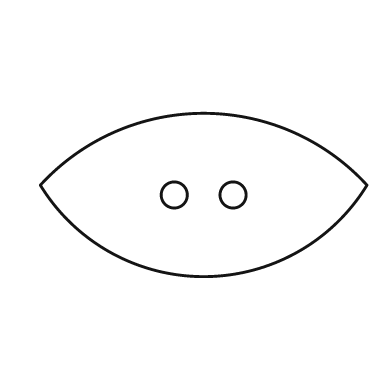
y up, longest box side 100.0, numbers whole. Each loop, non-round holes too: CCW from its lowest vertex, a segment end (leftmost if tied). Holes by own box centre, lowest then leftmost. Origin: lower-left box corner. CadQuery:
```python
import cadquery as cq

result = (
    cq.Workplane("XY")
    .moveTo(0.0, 28.0)
    .threePointArc((50.0, 0.0), (100.0, 28.0))
    .threePointArc((50.0, 50.0), (0.0, 28.0))
    .close()
    .moveTo(41.0, 25.0)
    .circle(4.0)
    .moveTo(59.0, 25.0)
    .circle(4.0)
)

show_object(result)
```